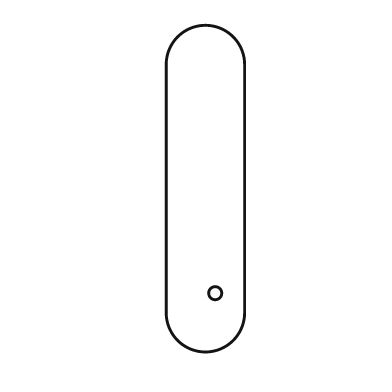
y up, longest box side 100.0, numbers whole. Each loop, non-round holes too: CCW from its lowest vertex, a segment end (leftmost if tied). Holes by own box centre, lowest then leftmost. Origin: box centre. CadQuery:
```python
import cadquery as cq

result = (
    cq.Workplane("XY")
    .moveTo(-12.0, -38.0)
    .threePointArc((0.0, -50.0), (12.0, -38.0))
    .lineTo(12.0, 38.0)
    .threePointArc((0.0, 50.0), (-12.0, 38.0))
    .close()
    .moveTo(3.0, -32.0)
    .circle(2.0)
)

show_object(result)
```